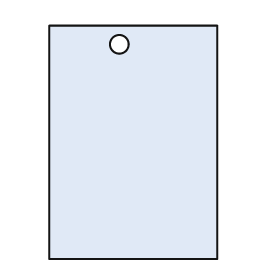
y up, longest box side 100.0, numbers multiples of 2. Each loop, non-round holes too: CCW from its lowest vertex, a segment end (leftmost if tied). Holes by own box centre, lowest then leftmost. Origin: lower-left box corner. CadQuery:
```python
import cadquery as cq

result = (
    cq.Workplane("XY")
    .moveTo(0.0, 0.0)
    .lineTo(72.0, 0.0)
    .lineTo(72.0, 100.0)
    .lineTo(0.0, 100.0)
    .close()
    .moveTo(30.0, 92.0)
    .circle(4.0)
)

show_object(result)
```